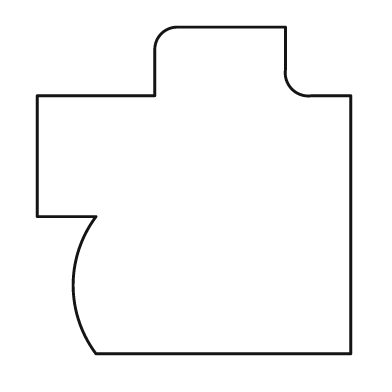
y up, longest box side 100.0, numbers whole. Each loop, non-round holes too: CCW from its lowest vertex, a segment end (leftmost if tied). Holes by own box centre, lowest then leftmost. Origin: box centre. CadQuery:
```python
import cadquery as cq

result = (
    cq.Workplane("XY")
    .moveTo(-30.0, -50.0)
    .lineTo(48.0, -50.0)
    .lineTo(48.0, 29.0)
    .lineTo(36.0, 29.0)
    .threePointArc((30.0, 31.0), (28.0, 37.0))
    .lineTo(28.0, 50.0)
    .lineTo(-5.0, 50.0)
    .threePointArc((-10.0, 48.0), (-12.0, 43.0))
    .lineTo(-12.0, 29.0)
    .lineTo(-48.0, 29.0)
    .lineTo(-48.0, -8.0)
    .lineTo(-30.0, -8.0)
    .threePointArc((-37.0, -29.0), (-30.0, -50.0))
    .close()
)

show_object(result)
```